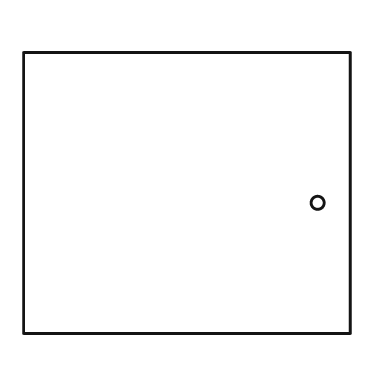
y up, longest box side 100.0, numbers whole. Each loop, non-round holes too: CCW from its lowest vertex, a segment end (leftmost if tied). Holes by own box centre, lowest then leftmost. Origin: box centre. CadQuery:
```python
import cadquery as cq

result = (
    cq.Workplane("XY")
    .moveTo(-50.0, -43.0)
    .lineTo(50.0, -43.0)
    .lineTo(50.0, 43.0)
    .lineTo(-50.0, 43.0)
    .close()
    .moveTo(40.0, -3.0)
    .circle(2.0)
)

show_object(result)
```